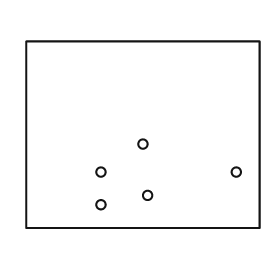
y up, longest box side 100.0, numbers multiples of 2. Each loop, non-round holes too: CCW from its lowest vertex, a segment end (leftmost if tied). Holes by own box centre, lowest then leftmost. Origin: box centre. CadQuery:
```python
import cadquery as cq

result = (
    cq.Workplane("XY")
    .moveTo(-50.0, -40.0)
    .lineTo(50.0, -40.0)
    .lineTo(50.0, 40.0)
    .lineTo(-50.0, 40.0)
    .close()
    .moveTo(-18.0, -30.0)
    .circle(2.0)
    .moveTo(2.0, -26.0)
    .circle(2.0)
    .moveTo(-18.0, -16.0)
    .circle(2.0)
    .moveTo(40.0, -16.0)
    .circle(2.0)
    .moveTo(0.0, -4.0)
    .circle(2.0)
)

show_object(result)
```